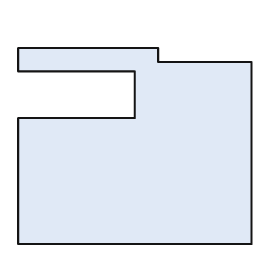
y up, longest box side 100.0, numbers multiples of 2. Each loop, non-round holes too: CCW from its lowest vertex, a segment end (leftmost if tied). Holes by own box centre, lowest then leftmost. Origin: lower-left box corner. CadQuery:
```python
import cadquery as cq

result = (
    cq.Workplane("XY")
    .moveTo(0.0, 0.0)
    .lineTo(100.0, 0.0)
    .lineTo(100.0, 78.0)
    .lineTo(60.0, 78.0)
    .lineTo(60.0, 84.0)
    .lineTo(0.0, 84.0)
    .lineTo(0.0, 74.0)
    .lineTo(50.0, 74.0)
    .lineTo(50.0, 54.0)
    .lineTo(0.0, 54.0)
    .close()
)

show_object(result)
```